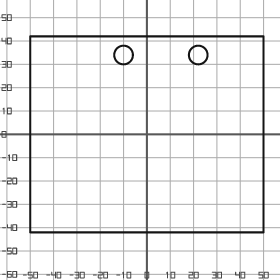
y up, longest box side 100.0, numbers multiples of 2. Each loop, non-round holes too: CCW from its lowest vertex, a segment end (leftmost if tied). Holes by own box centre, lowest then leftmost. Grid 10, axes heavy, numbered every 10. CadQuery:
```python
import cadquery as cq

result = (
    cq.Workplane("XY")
    .moveTo(-50.0, -42.0)
    .lineTo(50.0, -42.0)
    .lineTo(50.0, 42.0)
    .lineTo(-50.0, 42.0)
    .close()
    .moveTo(-10.0, 34.0)
    .circle(4.0)
    .moveTo(22.0, 34.0)
    .circle(4.0)
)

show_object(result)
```